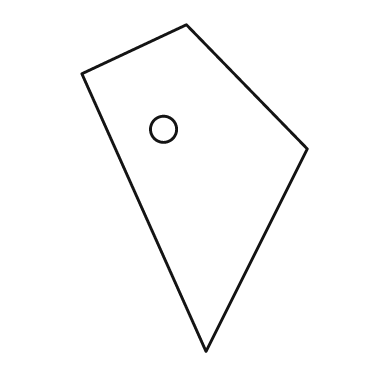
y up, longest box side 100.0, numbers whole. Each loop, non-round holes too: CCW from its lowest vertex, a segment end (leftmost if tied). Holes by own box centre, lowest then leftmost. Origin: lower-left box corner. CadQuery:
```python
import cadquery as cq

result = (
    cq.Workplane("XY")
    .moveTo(38.0, 0.0)
    .lineTo(69.0, 62.0)
    .lineTo(32.0, 100.0)
    .lineTo(0.0, 85.0)
    .close()
    .moveTo(25.0, 68.0)
    .circle(4.0)
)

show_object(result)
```